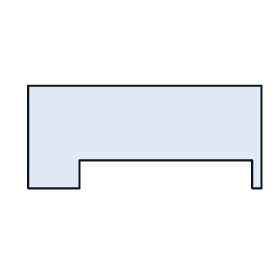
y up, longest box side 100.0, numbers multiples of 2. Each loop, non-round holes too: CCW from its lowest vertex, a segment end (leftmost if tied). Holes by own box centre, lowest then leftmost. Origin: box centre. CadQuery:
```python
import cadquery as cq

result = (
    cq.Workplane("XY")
    .moveTo(-50.0, -22.0)
    .lineTo(-28.0, -22.0)
    .lineTo(-28.0, -10.0)
    .lineTo(46.0, -10.0)
    .lineTo(46.0, -22.0)
    .lineTo(50.0, -22.0)
    .lineTo(50.0, 22.0)
    .lineTo(-50.0, 22.0)
    .close()
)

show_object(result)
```